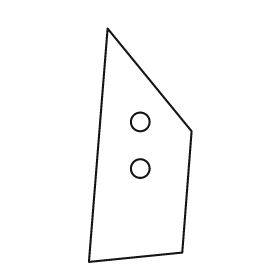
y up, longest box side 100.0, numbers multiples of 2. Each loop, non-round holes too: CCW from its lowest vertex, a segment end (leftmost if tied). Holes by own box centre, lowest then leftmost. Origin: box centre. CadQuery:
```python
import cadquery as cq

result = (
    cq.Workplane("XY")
    .moveTo(-22.0, -50.0)
    .lineTo(18.0, -46.0)
    .lineTo(22.0, 6.0)
    .lineTo(-14.0, 50.0)
    .close()
    .moveTo(0.0, -10.0)
    .circle(4.0)
    .moveTo(0.0, 10.0)
    .circle(4.0)
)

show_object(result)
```